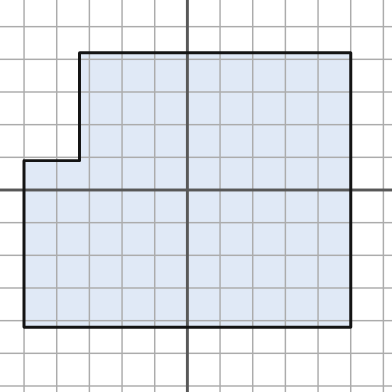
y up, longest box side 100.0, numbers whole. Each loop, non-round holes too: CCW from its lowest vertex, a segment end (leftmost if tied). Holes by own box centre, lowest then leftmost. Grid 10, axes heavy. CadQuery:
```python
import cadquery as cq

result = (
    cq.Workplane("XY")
    .moveTo(-50.0, -42.0)
    .lineTo(50.0, -42.0)
    .lineTo(50.0, 42.0)
    .lineTo(-33.0, 42.0)
    .lineTo(-33.0, 9.0)
    .lineTo(-50.0, 9.0)
    .close()
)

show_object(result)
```